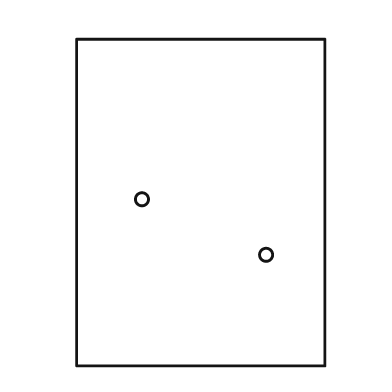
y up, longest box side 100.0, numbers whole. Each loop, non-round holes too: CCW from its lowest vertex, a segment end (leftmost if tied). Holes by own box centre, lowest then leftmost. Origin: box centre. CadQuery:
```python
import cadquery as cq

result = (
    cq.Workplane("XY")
    .moveTo(-38.0, -50.0)
    .lineTo(38.0, -50.0)
    .lineTo(38.0, 50.0)
    .lineTo(-38.0, 50.0)
    .close()
    .moveTo(20.0, -16.0)
    .circle(2.0)
    .moveTo(-18.0, 1.0)
    .circle(2.0)
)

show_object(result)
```